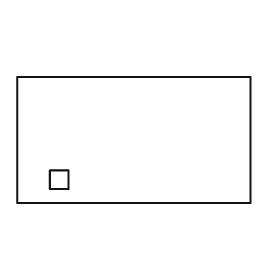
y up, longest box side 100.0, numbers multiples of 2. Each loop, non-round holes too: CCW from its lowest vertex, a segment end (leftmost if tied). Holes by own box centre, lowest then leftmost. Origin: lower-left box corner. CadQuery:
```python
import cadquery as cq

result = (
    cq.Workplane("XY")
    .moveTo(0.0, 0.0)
    .lineTo(100.0, 0.0)
    .lineTo(100.0, 54.0)
    .lineTo(0.0, 54.0)
    .close()
    .moveTo(14.0, 6.0)
    .lineTo(22.0, 6.0)
    .lineTo(22.0, 14.0)
    .lineTo(14.0, 14.0)
    .close()
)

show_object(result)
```